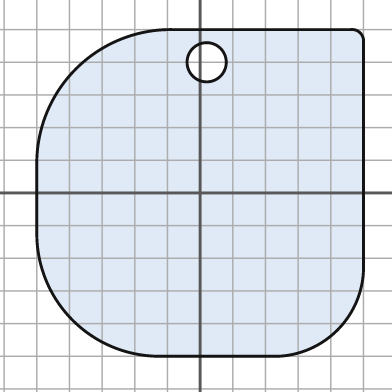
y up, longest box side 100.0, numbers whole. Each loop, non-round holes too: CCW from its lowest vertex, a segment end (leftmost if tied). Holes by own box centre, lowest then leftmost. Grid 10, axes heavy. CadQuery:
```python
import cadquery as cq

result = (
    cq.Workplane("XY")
    .moveTo(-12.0, -50.0)
    .lineTo(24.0, -50.0)
    .threePointArc((42.0, -42.0), (50.0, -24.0))
    .lineTo(50.0, 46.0)
    .threePointArc((49.0, 49.0), (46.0, 50.0))
    .lineTo(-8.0, 50.0)
    .threePointArc((-38.0, 38.0), (-50.0, 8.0))
    .lineTo(-50.0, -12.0)
    .threePointArc((-39.0, -39.0), (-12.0, -50.0))
    .close()
    .moveTo(2.0, 40.0)
    .circle(6.0)
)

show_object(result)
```